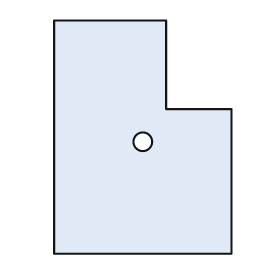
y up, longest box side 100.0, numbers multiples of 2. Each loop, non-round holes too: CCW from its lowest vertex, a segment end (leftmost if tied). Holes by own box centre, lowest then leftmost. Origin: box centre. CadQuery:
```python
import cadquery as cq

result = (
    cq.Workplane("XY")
    .moveTo(-38.0, -50.0)
    .lineTo(38.0, -50.0)
    .lineTo(38.0, 12.0)
    .lineTo(10.0, 12.0)
    .lineTo(10.0, 50.0)
    .lineTo(-38.0, 50.0)
    .close()
    .moveTo(0.0, -2.0)
    .circle(4.0)
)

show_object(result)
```